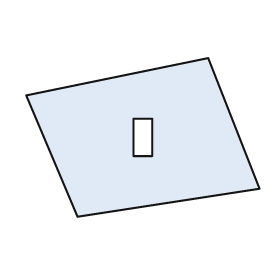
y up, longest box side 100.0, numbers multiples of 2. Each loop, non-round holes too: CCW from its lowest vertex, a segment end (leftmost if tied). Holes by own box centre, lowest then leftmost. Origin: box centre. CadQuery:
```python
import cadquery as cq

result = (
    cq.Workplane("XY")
    .moveTo(-28.0, -34.0)
    .lineTo(50.0, -22.0)
    .lineTo(28.0, 34.0)
    .lineTo(-50.0, 18.0)
    .close()
    .moveTo(-4.0, -8.0)
    .lineTo(4.0, -8.0)
    .lineTo(4.0, 8.0)
    .lineTo(-4.0, 8.0)
    .close()
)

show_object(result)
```